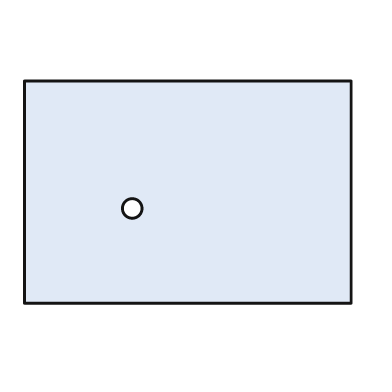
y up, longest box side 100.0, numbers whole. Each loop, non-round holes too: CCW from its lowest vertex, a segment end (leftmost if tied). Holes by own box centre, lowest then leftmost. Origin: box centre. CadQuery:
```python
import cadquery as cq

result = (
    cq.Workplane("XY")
    .moveTo(-50.0, -34.0)
    .lineTo(50.0, -34.0)
    .lineTo(50.0, 34.0)
    .lineTo(-50.0, 34.0)
    .close()
    .moveTo(-17.0, -5.0)
    .circle(3.0)
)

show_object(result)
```